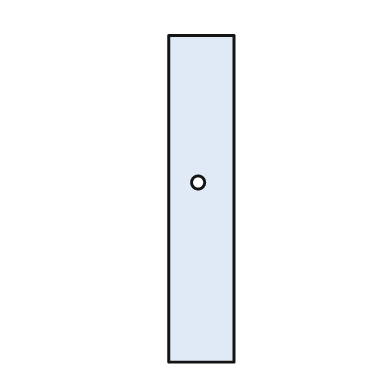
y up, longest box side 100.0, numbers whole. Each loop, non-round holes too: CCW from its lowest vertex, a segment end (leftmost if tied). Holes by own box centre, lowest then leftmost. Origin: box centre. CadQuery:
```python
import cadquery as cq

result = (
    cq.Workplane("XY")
    .moveTo(-10.0, -50.0)
    .lineTo(10.0, -50.0)
    .lineTo(10.0, 50.0)
    .lineTo(-10.0, 50.0)
    .close()
    .moveTo(-1.0, 5.0)
    .circle(2.0)
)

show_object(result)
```